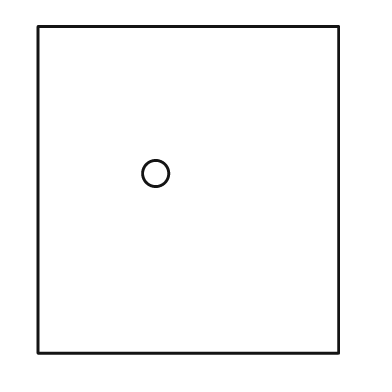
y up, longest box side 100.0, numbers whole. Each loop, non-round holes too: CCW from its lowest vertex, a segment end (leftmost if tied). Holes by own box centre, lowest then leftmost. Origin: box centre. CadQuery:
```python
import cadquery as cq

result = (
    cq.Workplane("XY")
    .moveTo(-46.0, -50.0)
    .lineTo(46.0, -50.0)
    .lineTo(46.0, 50.0)
    .lineTo(-46.0, 50.0)
    .close()
    .moveTo(-10.0, 5.0)
    .circle(4.0)
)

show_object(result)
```